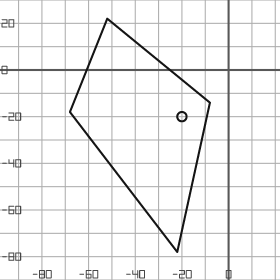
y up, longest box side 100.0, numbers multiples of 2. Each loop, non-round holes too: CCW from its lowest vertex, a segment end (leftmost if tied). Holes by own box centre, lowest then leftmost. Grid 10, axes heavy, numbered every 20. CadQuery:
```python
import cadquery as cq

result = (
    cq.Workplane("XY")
    .moveTo(-22.0, -78.0)
    .lineTo(-8.0, -14.0)
    .lineTo(-52.0, 22.0)
    .lineTo(-68.0, -18.0)
    .close()
    .moveTo(-20.0, -20.0)
    .circle(2.0)
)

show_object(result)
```